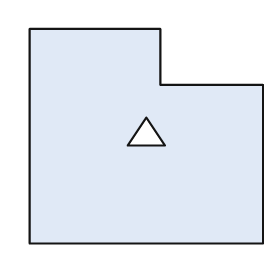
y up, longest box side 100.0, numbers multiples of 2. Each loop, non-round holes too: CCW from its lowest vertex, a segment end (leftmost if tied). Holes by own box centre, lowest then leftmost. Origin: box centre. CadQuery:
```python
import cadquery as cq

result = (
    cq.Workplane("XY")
    .moveTo(-50.0, -46.0)
    .lineTo(50.0, -46.0)
    .lineTo(50.0, 22.0)
    .lineTo(6.0, 22.0)
    .lineTo(6.0, 46.0)
    .lineTo(-50.0, 46.0)
    .close()
    .moveTo(-8.0, -4.0)
    .lineTo(8.0, -4.0)
    .lineTo(0.0, 8.0)
    .close()
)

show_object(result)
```